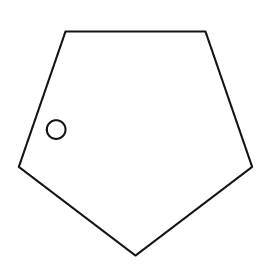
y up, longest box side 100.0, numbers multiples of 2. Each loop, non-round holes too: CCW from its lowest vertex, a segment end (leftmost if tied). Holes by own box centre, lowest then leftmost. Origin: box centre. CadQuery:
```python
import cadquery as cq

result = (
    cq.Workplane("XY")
    .moveTo(0.0, -48.0)
    .lineTo(50.0, -10.0)
    .lineTo(30.0, 48.0)
    .lineTo(-30.0, 48.0)
    .lineTo(-50.0, -10.0)
    .close()
    .moveTo(-34.0, 6.0)
    .circle(4.0)
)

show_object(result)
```